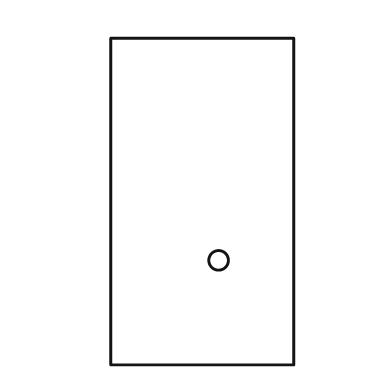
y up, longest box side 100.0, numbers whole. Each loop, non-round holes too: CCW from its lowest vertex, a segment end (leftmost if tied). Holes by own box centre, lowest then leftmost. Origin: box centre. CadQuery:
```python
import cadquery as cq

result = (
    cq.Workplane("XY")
    .moveTo(-28.0, -50.0)
    .lineTo(28.0, -50.0)
    .lineTo(28.0, 50.0)
    .lineTo(-28.0, 50.0)
    .close()
    .moveTo(5.0, -18.0)
    .circle(3.0)
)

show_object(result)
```